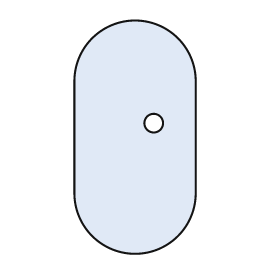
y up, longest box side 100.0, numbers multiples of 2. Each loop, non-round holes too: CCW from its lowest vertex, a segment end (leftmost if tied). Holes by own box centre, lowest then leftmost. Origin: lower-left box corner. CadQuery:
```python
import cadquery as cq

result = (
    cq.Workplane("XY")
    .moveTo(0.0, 26.0)
    .threePointArc((26.0, 0.0), (52.0, 26.0))
    .lineTo(52.0, 74.0)
    .threePointArc((26.0, 100.0), (0.0, 74.0))
    .close()
    .moveTo(34.0, 56.0)
    .circle(4.0)
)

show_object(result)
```